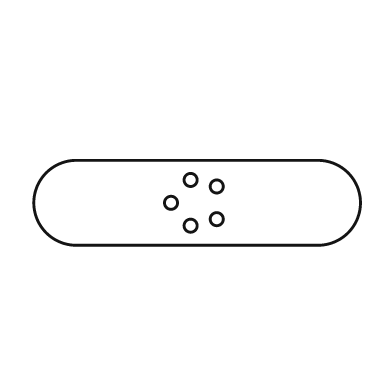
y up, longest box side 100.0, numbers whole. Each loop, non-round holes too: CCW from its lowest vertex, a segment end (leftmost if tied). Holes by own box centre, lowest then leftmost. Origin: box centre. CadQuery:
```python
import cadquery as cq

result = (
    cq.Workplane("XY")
    .moveTo(-37.0, -13.0)
    .lineTo(37.0, -13.0)
    .threePointArc((50.0, 0.0), (37.0, 13.0))
    .lineTo(-37.0, 13.0)
    .threePointArc((-50.0, 0.0), (-37.0, -13.0))
    .close()
    .moveTo(-2.0, -7.0)
    .circle(2.0)
    .moveTo(6.0, -5.0)
    .circle(2.0)
    .moveTo(-8.0, 0.0)
    .circle(2.0)
    .moveTo(6.0, 5.0)
    .circle(2.0)
    .moveTo(-2.0, 7.0)
    .circle(2.0)
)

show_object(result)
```